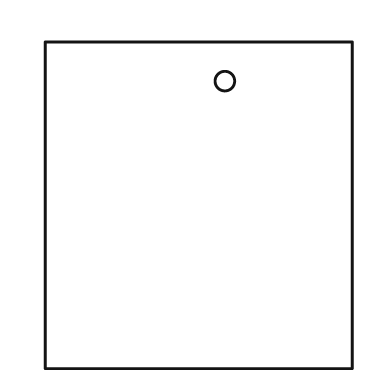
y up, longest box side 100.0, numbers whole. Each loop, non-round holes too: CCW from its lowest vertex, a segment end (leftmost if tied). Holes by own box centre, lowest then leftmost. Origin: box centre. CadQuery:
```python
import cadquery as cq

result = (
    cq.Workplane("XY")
    .moveTo(-47.0, -50.0)
    .lineTo(47.0, -50.0)
    .lineTo(47.0, 50.0)
    .lineTo(-47.0, 50.0)
    .close()
    .moveTo(8.0, 38.0)
    .circle(3.0)
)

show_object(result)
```